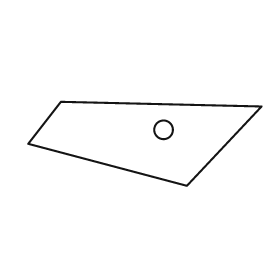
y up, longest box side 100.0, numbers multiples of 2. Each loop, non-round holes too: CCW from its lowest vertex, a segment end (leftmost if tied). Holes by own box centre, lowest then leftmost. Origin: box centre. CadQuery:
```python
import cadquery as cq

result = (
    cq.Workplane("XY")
    .moveTo(18.0, -18.0)
    .lineTo(50.0, 16.0)
    .lineTo(-36.0, 18.0)
    .lineTo(-50.0, 0.0)
    .close()
    .moveTo(8.0, 6.0)
    .circle(4.0)
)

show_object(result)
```